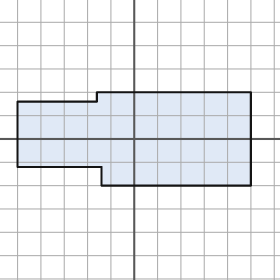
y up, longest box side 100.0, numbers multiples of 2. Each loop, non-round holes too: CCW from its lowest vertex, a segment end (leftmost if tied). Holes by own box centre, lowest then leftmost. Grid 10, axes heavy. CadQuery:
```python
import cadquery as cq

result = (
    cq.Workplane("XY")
    .moveTo(-14.0, -20.0)
    .lineTo(50.0, -20.0)
    .lineTo(50.0, 20.0)
    .lineTo(-16.0, 20.0)
    .lineTo(-16.0, 16.0)
    .lineTo(-50.0, 16.0)
    .lineTo(-50.0, -12.0)
    .lineTo(-14.0, -12.0)
    .close()
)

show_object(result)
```